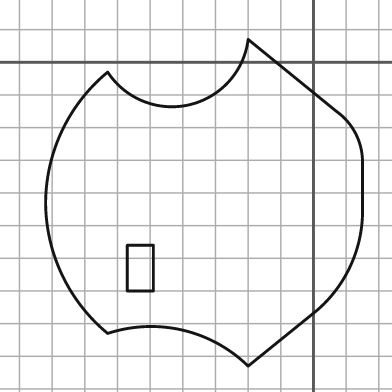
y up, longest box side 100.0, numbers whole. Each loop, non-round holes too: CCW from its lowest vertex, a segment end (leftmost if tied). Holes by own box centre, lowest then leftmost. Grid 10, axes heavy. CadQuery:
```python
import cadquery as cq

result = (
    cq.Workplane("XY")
    .moveTo(-20.0, -93.0)
    .lineTo(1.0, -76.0)
    .threePointArc((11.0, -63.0), (15.0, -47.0))
    .lineTo(15.0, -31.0)
    .threePointArc((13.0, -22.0), (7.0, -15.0))
    .lineTo(-20.0, 7.0)
    .threePointArc((-38.0, -13.0), (-63.0, -3.0))
    .threePointArc((-77.0, -21.0), (-82.0, -43.0))
    .threePointArc((-77.0, -65.0), (-63.0, -83.0))
    .threePointArc((-40.0, -82.0), (-20.0, -93.0))
    .close()
    .moveTo(-57.0, -70.0)
    .lineTo(-49.0, -70.0)
    .lineTo(-49.0, -56.0)
    .lineTo(-57.0, -56.0)
    .close()
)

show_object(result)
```